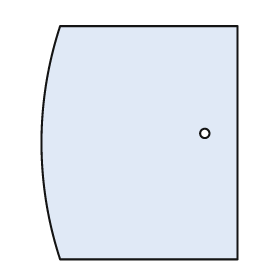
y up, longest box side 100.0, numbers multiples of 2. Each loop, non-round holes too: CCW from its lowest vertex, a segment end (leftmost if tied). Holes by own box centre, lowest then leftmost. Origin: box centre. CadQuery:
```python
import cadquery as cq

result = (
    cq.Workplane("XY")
    .moveTo(-34.0, -50.0)
    .lineTo(42.0, -50.0)
    .lineTo(42.0, 50.0)
    .lineTo(-34.0, 50.0)
    .threePointArc((-42.0, 0.0), (-34.0, -50.0))
    .close()
    .moveTo(28.0, 4.0)
    .circle(2.0)
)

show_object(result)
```